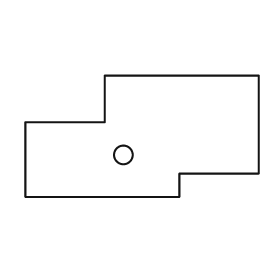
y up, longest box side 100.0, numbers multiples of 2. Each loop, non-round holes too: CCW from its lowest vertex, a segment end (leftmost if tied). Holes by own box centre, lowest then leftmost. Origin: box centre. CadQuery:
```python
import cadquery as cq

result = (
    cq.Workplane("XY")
    .moveTo(-50.0, -26.0)
    .lineTo(16.0, -26.0)
    .lineTo(16.0, -16.0)
    .lineTo(50.0, -16.0)
    .lineTo(50.0, 26.0)
    .lineTo(-16.0, 26.0)
    .lineTo(-16.0, 6.0)
    .lineTo(-50.0, 6.0)
    .close()
    .moveTo(-8.0, -8.0)
    .circle(4.0)
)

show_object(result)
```